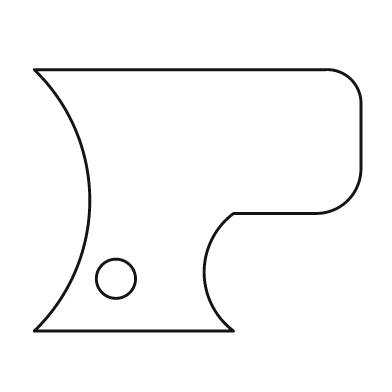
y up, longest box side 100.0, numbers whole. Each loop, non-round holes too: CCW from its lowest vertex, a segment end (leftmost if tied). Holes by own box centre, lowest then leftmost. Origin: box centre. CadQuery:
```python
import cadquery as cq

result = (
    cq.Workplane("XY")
    .moveTo(-50.0, -40.0)
    .lineTo(11.0, -40.0)
    .threePointArc((2.0, -22.0), (11.0, -4.0))
    .lineTo(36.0, -4.0)
    .threePointArc((46.0, 0.0), (50.0, 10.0))
    .lineTo(50.0, 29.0)
    .threePointArc((47.0, 37.0), (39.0, 40.0))
    .lineTo(-50.0, 40.0)
    .threePointArc((-33.0, 0.0), (-50.0, -40.0))
    .close()
    .moveTo(-25.0, -24.0)
    .circle(6.0)
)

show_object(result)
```